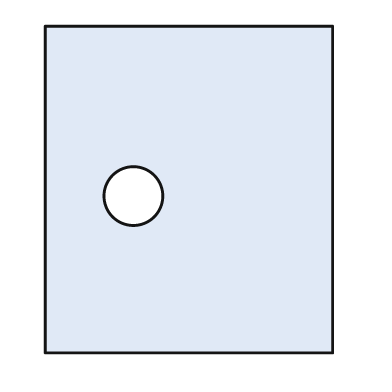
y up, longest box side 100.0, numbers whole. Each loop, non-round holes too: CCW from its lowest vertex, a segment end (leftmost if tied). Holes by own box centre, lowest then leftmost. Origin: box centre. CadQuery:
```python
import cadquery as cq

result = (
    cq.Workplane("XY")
    .moveTo(-44.0, -50.0)
    .lineTo(44.0, -50.0)
    .lineTo(44.0, 50.0)
    .lineTo(-44.0, 50.0)
    .close()
    .moveTo(-17.0, -2.0)
    .circle(9.0)
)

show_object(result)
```